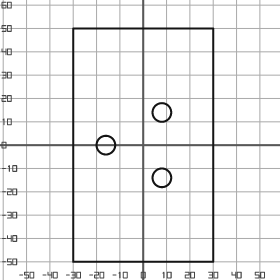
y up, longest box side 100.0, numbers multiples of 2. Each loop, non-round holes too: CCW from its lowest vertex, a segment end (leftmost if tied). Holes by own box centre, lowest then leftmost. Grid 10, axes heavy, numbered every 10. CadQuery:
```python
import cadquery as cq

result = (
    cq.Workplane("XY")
    .moveTo(-30.0, -50.0)
    .lineTo(30.0, -50.0)
    .lineTo(30.0, 50.0)
    .lineTo(-30.0, 50.0)
    .close()
    .moveTo(8.0, -14.0)
    .circle(4.0)
    .moveTo(-16.0, 0.0)
    .circle(4.0)
    .moveTo(8.0, 14.0)
    .circle(4.0)
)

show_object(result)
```